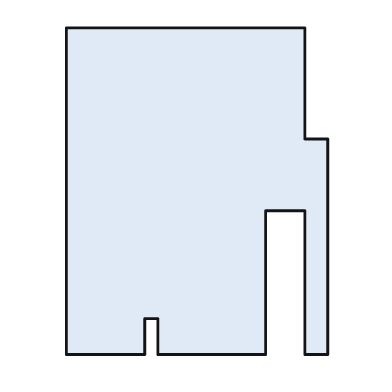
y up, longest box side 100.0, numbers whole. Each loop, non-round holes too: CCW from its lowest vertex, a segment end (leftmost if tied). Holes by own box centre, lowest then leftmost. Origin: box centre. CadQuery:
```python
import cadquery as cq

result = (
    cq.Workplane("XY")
    .moveTo(-40.0, -50.0)
    .lineTo(-16.0, -50.0)
    .lineTo(-16.0, -39.0)
    .lineTo(-12.0, -39.0)
    .lineTo(-12.0, -50.0)
    .lineTo(21.0, -50.0)
    .lineTo(21.0, -6.0)
    .lineTo(33.0, -6.0)
    .lineTo(33.0, -50.0)
    .lineTo(40.0, -50.0)
    .lineTo(40.0, 16.0)
    .lineTo(33.0, 16.0)
    .lineTo(33.0, 50.0)
    .lineTo(-40.0, 50.0)
    .close()
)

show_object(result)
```